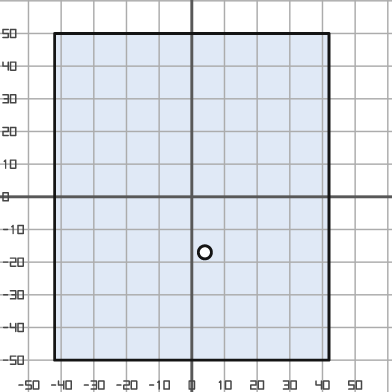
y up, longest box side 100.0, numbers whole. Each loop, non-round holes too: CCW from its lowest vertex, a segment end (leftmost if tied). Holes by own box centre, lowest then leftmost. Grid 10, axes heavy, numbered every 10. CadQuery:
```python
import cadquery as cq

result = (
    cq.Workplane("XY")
    .moveTo(-42.0, -50.0)
    .lineTo(42.0, -50.0)
    .lineTo(42.0, 50.0)
    .lineTo(-42.0, 50.0)
    .close()
    .moveTo(4.0, -17.0)
    .circle(2.0)
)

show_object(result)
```